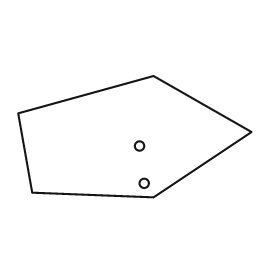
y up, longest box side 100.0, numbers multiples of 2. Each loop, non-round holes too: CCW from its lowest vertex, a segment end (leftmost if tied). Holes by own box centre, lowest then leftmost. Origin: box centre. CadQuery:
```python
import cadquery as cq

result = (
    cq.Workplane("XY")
    .moveTo(8.0, -26.0)
    .lineTo(50.0, 2.0)
    .lineTo(8.0, 26.0)
    .lineTo(-50.0, 10.0)
    .lineTo(-44.0, -24.0)
    .close()
    .moveTo(4.0, -20.0)
    .circle(2.0)
    .moveTo(2.0, -4.0)
    .circle(2.0)
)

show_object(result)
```